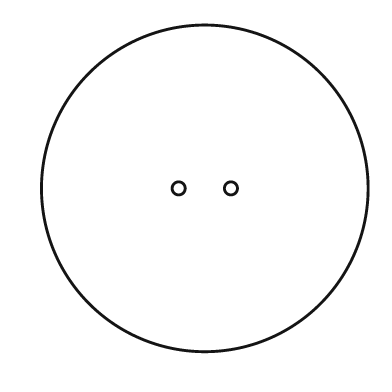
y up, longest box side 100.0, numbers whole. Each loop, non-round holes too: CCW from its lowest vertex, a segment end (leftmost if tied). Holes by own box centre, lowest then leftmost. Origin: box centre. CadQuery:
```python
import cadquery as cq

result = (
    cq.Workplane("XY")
    .moveTo(0.0, 0.0)
    .circle(50.0)
    .moveTo(-8.0, 0.0)
    .circle(2.0)
    .moveTo(8.0, 0.0)
    .circle(2.0)
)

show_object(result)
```